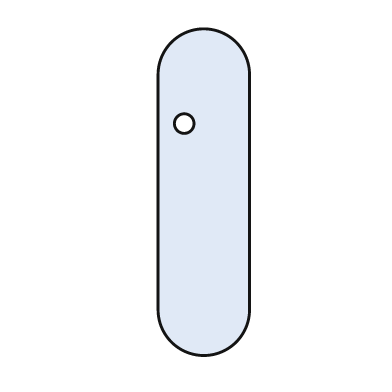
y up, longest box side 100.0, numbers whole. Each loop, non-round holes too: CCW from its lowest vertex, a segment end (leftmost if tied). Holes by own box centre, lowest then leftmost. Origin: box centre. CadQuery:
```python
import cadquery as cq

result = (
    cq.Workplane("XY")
    .moveTo(-14.0, -36.0)
    .threePointArc((0.0, -50.0), (14.0, -36.0))
    .lineTo(14.0, 36.0)
    .threePointArc((0.0, 50.0), (-14.0, 36.0))
    .close()
    .moveTo(-6.0, 21.0)
    .circle(3.0)
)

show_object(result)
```